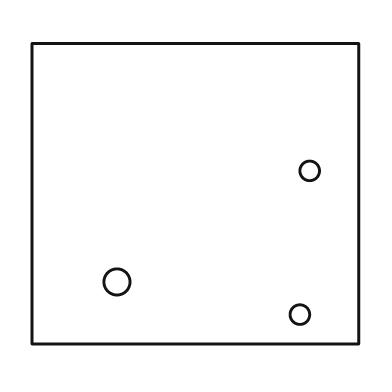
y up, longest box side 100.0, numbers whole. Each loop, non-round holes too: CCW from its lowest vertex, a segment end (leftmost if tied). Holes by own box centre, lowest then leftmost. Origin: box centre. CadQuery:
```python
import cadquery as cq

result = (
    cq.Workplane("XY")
    .moveTo(-50.0, -46.0)
    .lineTo(50.0, -46.0)
    .lineTo(50.0, 46.0)
    .lineTo(-50.0, 46.0)
    .close()
    .moveTo(32.0, -37.0)
    .circle(3.0)
    .moveTo(-24.0, -27.0)
    .circle(4.0)
    .moveTo(35.0, 7.0)
    .circle(3.0)
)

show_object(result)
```